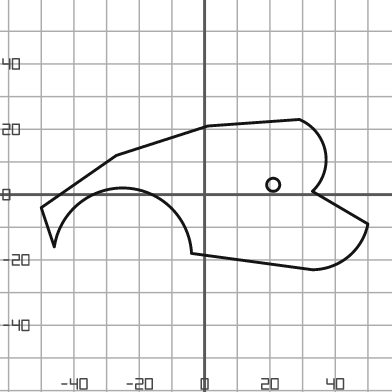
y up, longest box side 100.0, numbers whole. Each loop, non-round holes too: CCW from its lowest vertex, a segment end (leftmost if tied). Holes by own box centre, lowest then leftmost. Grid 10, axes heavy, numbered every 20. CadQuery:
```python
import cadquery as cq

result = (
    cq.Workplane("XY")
    .moveTo(33.0, -23.0)
    .threePointArc((44.0, -19.0), (50.0, -9.0))
    .lineTo(33.0, 1.0)
    .threePointArc((37.0, 13.0), (29.0, 23.0))
    .lineTo(1.0, 21.0)
    .lineTo(-27.0, 12.0)
    .lineTo(-50.0, -4.0)
    .lineTo(-46.0, -16.0)
    .threePointArc((-24.0, 2.0), (-4.0, -18.0))
    .close()
    .moveTo(21.0, 3.0)
    .circle(2.0)
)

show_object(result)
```